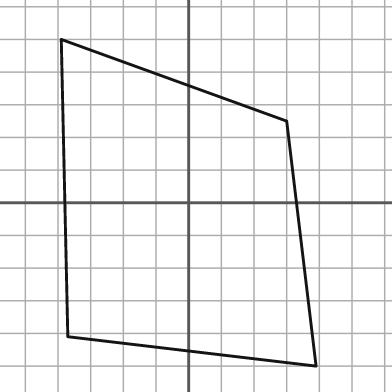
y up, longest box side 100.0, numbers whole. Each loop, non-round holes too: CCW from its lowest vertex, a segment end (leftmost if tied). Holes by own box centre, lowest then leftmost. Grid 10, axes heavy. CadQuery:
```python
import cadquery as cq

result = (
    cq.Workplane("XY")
    .moveTo(39.0, -50.0)
    .lineTo(30.0, 25.0)
    .lineTo(-39.0, 50.0)
    .lineTo(-37.0, -41.0)
    .close()
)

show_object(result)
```